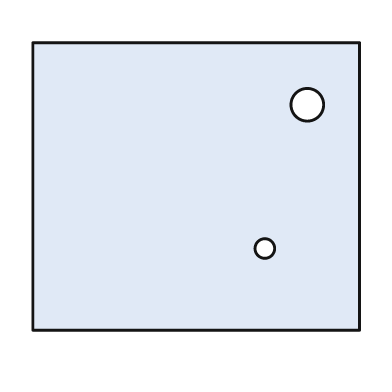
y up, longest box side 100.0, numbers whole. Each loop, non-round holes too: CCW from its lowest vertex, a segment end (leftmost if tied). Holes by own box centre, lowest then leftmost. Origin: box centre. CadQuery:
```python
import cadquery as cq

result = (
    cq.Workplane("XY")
    .moveTo(-50.0, -44.0)
    .lineTo(50.0, -44.0)
    .lineTo(50.0, 44.0)
    .lineTo(-50.0, 44.0)
    .close()
    .moveTo(21.0, -19.0)
    .circle(3.0)
    .moveTo(34.0, 25.0)
    .circle(5.0)
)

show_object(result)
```